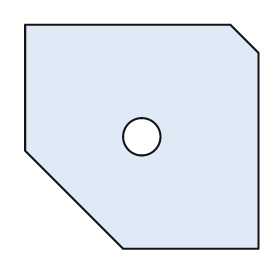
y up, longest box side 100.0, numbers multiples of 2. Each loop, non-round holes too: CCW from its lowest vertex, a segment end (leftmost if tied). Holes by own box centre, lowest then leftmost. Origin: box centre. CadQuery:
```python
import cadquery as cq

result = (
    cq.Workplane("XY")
    .moveTo(-8.0, -48.0)
    .lineTo(50.0, -48.0)
    .lineTo(50.0, 36.0)
    .lineTo(38.0, 48.0)
    .lineTo(-50.0, 48.0)
    .lineTo(-50.0, -6.0)
    .close()
    .moveTo(0.0, 0.0)
    .circle(8.0)
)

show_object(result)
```